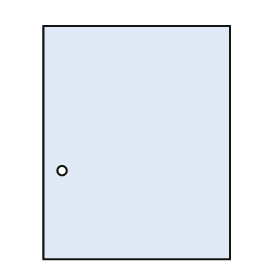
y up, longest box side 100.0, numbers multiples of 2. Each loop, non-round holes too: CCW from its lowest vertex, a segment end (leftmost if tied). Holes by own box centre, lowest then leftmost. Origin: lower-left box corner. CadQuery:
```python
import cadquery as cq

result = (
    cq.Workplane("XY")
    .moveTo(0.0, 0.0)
    .lineTo(80.0, 0.0)
    .lineTo(80.0, 100.0)
    .lineTo(0.0, 100.0)
    .close()
    .moveTo(8.0, 38.0)
    .circle(2.0)
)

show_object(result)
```